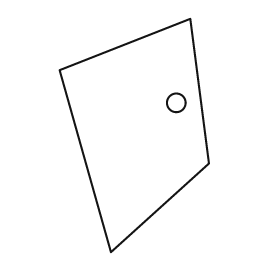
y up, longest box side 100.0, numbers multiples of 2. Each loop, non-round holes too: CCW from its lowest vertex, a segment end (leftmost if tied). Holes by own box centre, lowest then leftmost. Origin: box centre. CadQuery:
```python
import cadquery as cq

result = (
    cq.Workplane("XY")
    .moveTo(-10.0, -50.0)
    .lineTo(32.0, -12.0)
    .lineTo(24.0, 50.0)
    .lineTo(-32.0, 28.0)
    .close()
    .moveTo(18.0, 14.0)
    .circle(4.0)
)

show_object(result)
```